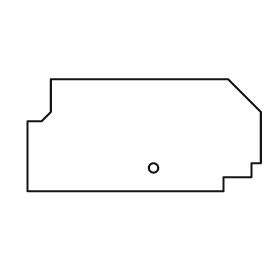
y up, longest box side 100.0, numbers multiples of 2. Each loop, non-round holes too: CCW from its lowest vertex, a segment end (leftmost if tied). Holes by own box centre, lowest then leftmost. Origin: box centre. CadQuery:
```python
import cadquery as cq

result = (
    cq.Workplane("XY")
    .moveTo(-50.0, -24.0)
    .lineTo(34.0, -24.0)
    .lineTo(34.0, -18.0)
    .lineTo(46.0, -18.0)
    .lineTo(46.0, -12.0)
    .lineTo(50.0, -12.0)
    .lineTo(50.0, 10.0)
    .lineTo(36.0, 24.0)
    .lineTo(-40.0, 24.0)
    .lineTo(-40.0, 10.0)
    .lineTo(-44.0, 6.0)
    .lineTo(-50.0, 6.0)
    .close()
    .moveTo(4.0, -14.0)
    .circle(2.0)
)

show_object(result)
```